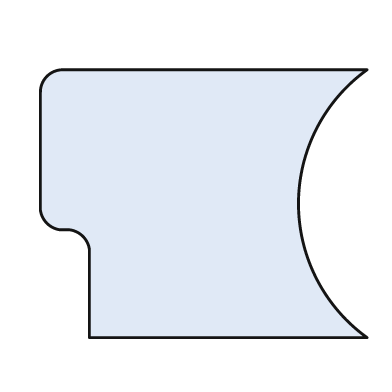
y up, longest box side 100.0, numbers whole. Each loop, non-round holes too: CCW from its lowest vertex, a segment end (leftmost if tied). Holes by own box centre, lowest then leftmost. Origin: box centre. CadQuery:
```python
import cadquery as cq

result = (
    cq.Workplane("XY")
    .moveTo(-35.0, -41.0)
    .lineTo(50.0, -41.0)
    .threePointArc((29.0, 0.0), (50.0, 41.0))
    .lineTo(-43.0, 41.0)
    .threePointArc((-48.0, 39.0), (-50.0, 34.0))
    .lineTo(-50.0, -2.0)
    .threePointArc((-48.0, -6.0), (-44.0, -8.0))
    .lineTo(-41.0, -8.0)
    .threePointArc((-37.0, -10.0), (-35.0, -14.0))
    .close()
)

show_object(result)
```